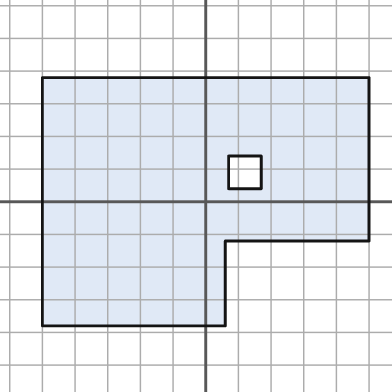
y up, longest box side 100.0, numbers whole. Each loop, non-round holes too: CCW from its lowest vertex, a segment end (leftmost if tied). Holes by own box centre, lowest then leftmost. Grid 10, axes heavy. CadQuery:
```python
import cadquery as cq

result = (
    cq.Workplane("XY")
    .moveTo(-50.0, -38.0)
    .lineTo(6.0, -38.0)
    .lineTo(6.0, -12.0)
    .lineTo(50.0, -12.0)
    .lineTo(50.0, 38.0)
    .lineTo(-50.0, 38.0)
    .close()
    .moveTo(7.0, 4.0)
    .lineTo(17.0, 4.0)
    .lineTo(17.0, 14.0)
    .lineTo(7.0, 14.0)
    .close()
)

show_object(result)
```